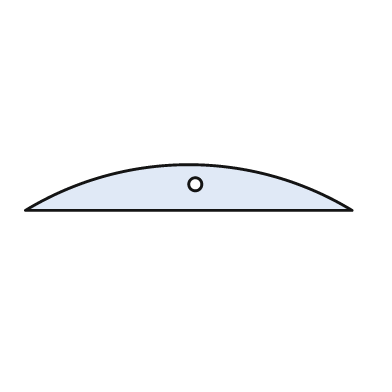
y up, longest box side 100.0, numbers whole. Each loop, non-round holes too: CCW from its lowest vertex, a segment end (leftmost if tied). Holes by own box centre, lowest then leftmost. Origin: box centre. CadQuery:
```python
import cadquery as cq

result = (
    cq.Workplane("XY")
    .moveTo(-50.0, -7.0)
    .lineTo(50.0, -7.0)
    .threePointArc((0.0, 7.0), (-50.0, -7.0))
    .close()
    .moveTo(2.0, 1.0)
    .circle(2.0)
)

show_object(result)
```